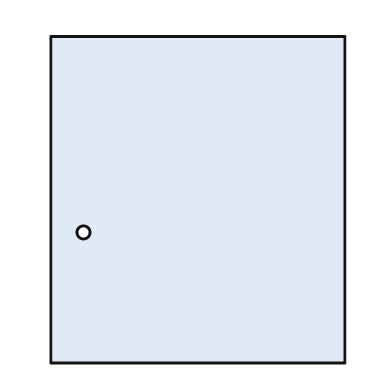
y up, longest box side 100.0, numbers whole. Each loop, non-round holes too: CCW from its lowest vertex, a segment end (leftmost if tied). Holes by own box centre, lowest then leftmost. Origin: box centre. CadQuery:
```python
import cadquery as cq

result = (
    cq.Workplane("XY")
    .moveTo(-45.0, -50.0)
    .lineTo(45.0, -50.0)
    .lineTo(45.0, 50.0)
    .lineTo(-45.0, 50.0)
    .close()
    .moveTo(-35.0, -10.0)
    .circle(2.0)
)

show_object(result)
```